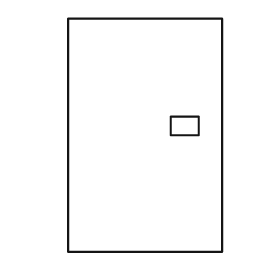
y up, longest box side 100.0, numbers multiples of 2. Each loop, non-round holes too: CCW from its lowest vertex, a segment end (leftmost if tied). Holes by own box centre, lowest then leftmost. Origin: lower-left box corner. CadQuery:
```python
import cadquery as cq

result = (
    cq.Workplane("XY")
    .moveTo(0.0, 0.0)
    .lineTo(66.0, 0.0)
    .lineTo(66.0, 100.0)
    .lineTo(0.0, 100.0)
    .close()
    .moveTo(44.0, 50.0)
    .lineTo(56.0, 50.0)
    .lineTo(56.0, 58.0)
    .lineTo(44.0, 58.0)
    .close()
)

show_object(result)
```